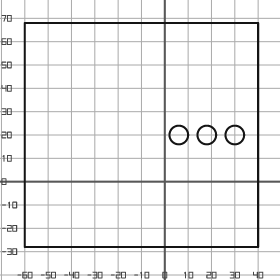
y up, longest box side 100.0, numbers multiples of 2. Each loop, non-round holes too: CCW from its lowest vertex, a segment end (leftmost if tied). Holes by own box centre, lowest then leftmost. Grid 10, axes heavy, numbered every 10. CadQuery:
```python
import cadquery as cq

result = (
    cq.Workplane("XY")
    .moveTo(-60.0, -28.0)
    .lineTo(40.0, -28.0)
    .lineTo(40.0, 68.0)
    .lineTo(-60.0, 68.0)
    .close()
    .moveTo(6.0, 20.0)
    .circle(4.0)
    .moveTo(18.0, 20.0)
    .circle(4.0)
    .moveTo(30.0, 20.0)
    .circle(4.0)
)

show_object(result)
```